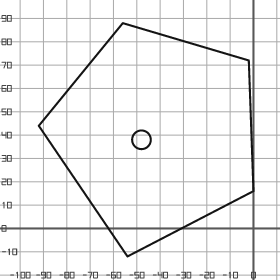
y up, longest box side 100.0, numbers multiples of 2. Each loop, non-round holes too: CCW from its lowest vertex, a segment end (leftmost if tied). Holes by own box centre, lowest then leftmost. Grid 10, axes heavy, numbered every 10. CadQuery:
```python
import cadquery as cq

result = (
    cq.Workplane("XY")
    .moveTo(-54.0, -12.0)
    .lineTo(0.0, 16.0)
    .lineTo(-2.0, 72.0)
    .lineTo(-56.0, 88.0)
    .lineTo(-92.0, 44.0)
    .close()
    .moveTo(-48.0, 38.0)
    .circle(4.0)
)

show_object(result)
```